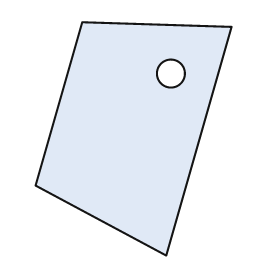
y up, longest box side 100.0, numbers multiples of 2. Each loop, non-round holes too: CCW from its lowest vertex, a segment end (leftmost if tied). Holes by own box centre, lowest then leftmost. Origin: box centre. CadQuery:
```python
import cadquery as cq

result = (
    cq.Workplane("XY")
    .moveTo(14.0, -50.0)
    .lineTo(42.0, 48.0)
    .lineTo(-22.0, 50.0)
    .lineTo(-42.0, -20.0)
    .close()
    .moveTo(16.0, 28.0)
    .circle(6.0)
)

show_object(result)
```